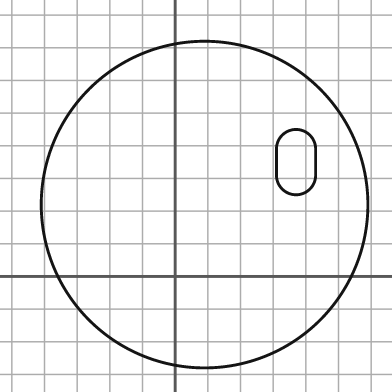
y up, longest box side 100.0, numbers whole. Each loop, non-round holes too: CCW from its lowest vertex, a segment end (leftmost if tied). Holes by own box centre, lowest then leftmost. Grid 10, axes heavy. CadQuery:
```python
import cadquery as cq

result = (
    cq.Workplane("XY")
    .moveTo(9.0, 22.0)
    .circle(50.0)
    .moveTo(31.0, 31.0)
    .threePointArc((37.0, 25.0), (43.0, 31.0))
    .lineTo(43.0, 39.0)
    .threePointArc((37.0, 45.0), (31.0, 39.0))
    .close()
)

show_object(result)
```